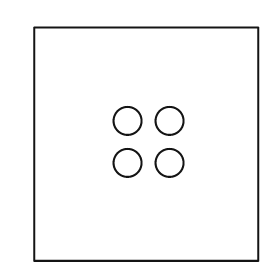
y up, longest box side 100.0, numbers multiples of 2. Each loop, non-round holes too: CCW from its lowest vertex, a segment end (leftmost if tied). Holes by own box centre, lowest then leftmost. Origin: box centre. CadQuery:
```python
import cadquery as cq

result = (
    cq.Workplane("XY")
    .moveTo(-48.0, -50.0)
    .lineTo(48.0, -50.0)
    .lineTo(48.0, 50.0)
    .lineTo(-48.0, 50.0)
    .close()
    .moveTo(-8.0, -8.0)
    .circle(6.0)
    .moveTo(10.0, -8.0)
    .circle(6.0)
    .moveTo(-8.0, 10.0)
    .circle(6.0)
    .moveTo(10.0, 10.0)
    .circle(6.0)
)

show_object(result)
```